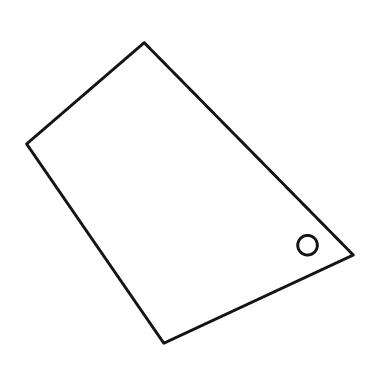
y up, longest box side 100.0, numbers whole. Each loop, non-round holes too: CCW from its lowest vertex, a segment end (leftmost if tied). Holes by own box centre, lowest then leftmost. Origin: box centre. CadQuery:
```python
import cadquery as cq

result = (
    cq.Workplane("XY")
    .moveTo(-8.0, -46.0)
    .lineTo(50.0, -19.0)
    .lineTo(-14.0, 46.0)
    .lineTo(-50.0, 15.0)
    .close()
    .moveTo(36.0, -16.0)
    .circle(3.0)
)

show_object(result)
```